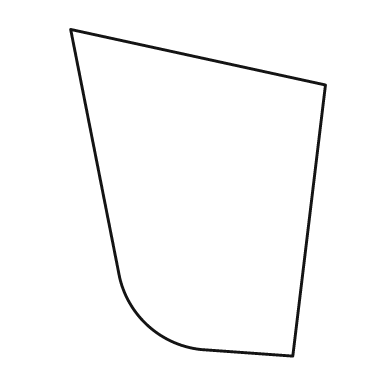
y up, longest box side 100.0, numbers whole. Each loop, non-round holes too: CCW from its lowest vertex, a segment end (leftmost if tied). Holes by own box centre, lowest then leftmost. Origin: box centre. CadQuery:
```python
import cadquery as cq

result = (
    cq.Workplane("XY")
    .moveTo(29.0, -50.0)
    .lineTo(39.0, 33.0)
    .lineTo(-39.0, 50.0)
    .lineTo(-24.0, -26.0)
    .threePointArc((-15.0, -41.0), (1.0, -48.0))
    .close()
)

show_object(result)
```